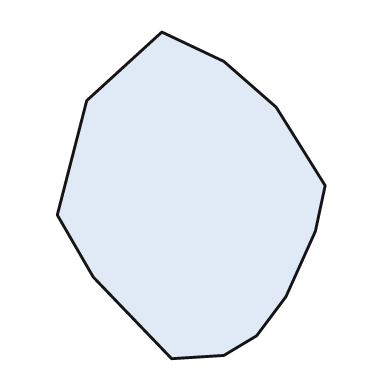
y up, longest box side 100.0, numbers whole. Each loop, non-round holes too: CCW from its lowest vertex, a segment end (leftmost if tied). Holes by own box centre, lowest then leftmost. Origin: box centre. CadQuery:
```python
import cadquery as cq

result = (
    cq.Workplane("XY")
    .moveTo(-6.0, -50.0)
    .lineTo(10.0, -49.0)
    .lineTo(20.0, -43.0)
    .lineTo(29.0, -31.0)
    .lineTo(38.0, -11.0)
    .lineTo(41.0, 3.0)
    .lineTo(26.0, 27.0)
    .lineTo(10.0, 41.0)
    .lineTo(-9.0, 50.0)
    .lineTo(-32.0, 29.0)
    .lineTo(-41.0, -6.0)
    .lineTo(-30.0, -25.0)
    .close()
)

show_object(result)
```